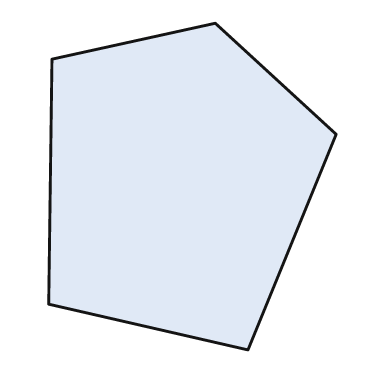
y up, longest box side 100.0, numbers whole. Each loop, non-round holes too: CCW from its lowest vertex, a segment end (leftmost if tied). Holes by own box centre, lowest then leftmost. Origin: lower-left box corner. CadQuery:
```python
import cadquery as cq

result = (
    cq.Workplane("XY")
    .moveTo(61.0, 0.0)
    .lineTo(88.0, 66.0)
    .lineTo(51.0, 100.0)
    .lineTo(1.0, 89.0)
    .lineTo(0.0, 14.0)
    .close()
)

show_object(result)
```